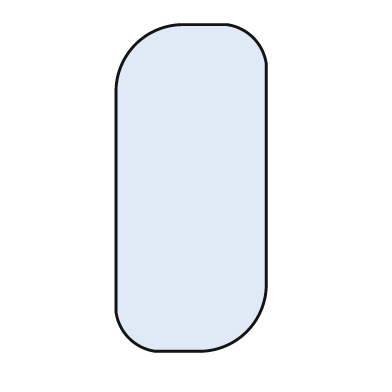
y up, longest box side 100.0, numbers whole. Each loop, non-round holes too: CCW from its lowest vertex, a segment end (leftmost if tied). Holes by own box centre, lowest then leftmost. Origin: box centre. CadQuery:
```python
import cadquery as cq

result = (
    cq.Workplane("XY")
    .moveTo(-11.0, -50.0)
    .lineTo(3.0, -50.0)
    .threePointArc((17.0, -44.0), (23.0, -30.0))
    .lineTo(23.0, 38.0)
    .threePointArc((19.0, 46.0), (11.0, 50.0))
    .lineTo(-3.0, 50.0)
    .threePointArc((-17.0, 44.0), (-23.0, 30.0))
    .lineTo(-23.0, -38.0)
    .threePointArc((-19.0, -46.0), (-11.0, -50.0))
    .close()
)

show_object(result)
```